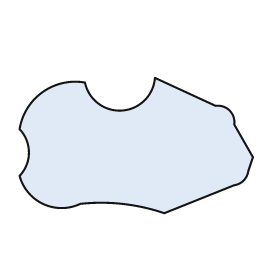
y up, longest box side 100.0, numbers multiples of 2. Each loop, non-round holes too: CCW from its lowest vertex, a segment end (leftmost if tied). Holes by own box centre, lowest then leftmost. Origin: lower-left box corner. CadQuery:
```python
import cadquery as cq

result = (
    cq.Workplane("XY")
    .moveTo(62.0, 0.0)
    .lineTo(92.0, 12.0)
    .threePointArc((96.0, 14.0), (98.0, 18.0))
    .lineTo(100.0, 24.0)
    .lineTo(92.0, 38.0)
    .threePointArc((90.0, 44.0), (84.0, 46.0))
    .lineTo(58.0, 58.0)
    .threePointArc((44.0, 44.0), (28.0, 56.0))
    .threePointArc((10.0, 52.0), (0.0, 36.0))
    .threePointArc((4.0, 26.0), (0.0, 16.0))
    .threePointArc((10.0, 4.0), (26.0, 4.0))
    .threePointArc((44.0, 4.0), (62.0, 0.0))
    .close()
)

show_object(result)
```